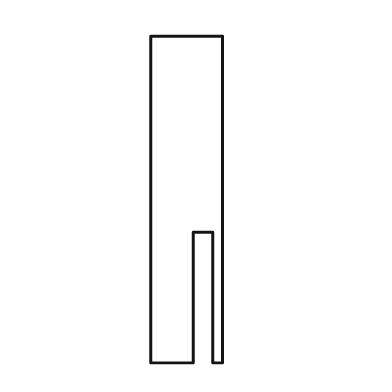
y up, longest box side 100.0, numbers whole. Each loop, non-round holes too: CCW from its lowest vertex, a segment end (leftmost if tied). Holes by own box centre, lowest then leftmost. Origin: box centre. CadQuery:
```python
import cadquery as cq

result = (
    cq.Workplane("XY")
    .moveTo(-11.0, -50.0)
    .lineTo(2.0, -50.0)
    .lineTo(2.0, -10.0)
    .lineTo(8.0, -10.0)
    .lineTo(8.0, -50.0)
    .lineTo(11.0, -50.0)
    .lineTo(11.0, 50.0)
    .lineTo(-11.0, 50.0)
    .close()
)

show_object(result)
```